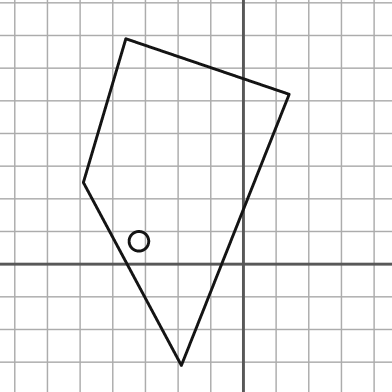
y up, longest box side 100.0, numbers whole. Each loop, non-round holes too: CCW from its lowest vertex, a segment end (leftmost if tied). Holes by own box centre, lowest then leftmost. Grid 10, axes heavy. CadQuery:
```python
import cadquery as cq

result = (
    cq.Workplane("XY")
    .moveTo(-19.0, -31.0)
    .lineTo(14.0, 52.0)
    .lineTo(-36.0, 69.0)
    .lineTo(-49.0, 25.0)
    .close()
    .moveTo(-32.0, 7.0)
    .circle(3.0)
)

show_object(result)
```